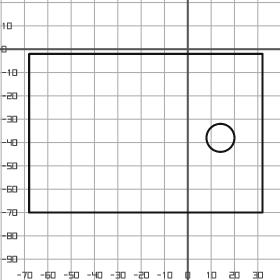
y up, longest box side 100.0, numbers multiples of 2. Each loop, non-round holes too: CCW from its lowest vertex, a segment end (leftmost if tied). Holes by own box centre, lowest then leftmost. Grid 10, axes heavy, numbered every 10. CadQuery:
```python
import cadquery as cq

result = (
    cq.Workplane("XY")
    .moveTo(-68.0, -70.0)
    .lineTo(32.0, -70.0)
    .lineTo(32.0, -2.0)
    .lineTo(-68.0, -2.0)
    .close()
    .moveTo(14.0, -38.0)
    .circle(6.0)
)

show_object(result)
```